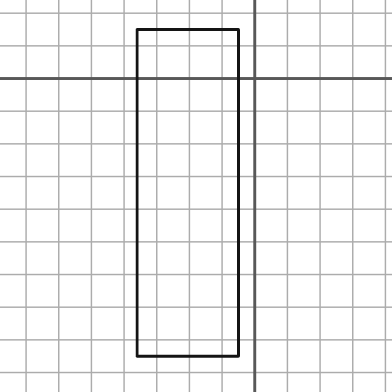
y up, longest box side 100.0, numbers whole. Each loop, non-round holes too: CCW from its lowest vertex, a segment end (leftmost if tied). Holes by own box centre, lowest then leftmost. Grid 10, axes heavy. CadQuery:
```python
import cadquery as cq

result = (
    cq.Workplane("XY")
    .moveTo(-36.0, -85.0)
    .lineTo(-5.0, -85.0)
    .lineTo(-5.0, 15.0)
    .lineTo(-36.0, 15.0)
    .close()
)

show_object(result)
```